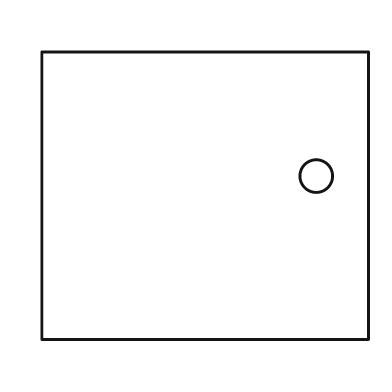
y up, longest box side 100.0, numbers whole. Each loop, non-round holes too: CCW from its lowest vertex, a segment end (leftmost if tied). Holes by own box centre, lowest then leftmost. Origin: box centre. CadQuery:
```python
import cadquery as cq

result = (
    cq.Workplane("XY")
    .moveTo(-50.0, -44.0)
    .lineTo(50.0, -44.0)
    .lineTo(50.0, 44.0)
    .lineTo(-50.0, 44.0)
    .close()
    .moveTo(34.0, 6.0)
    .circle(5.0)
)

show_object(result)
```